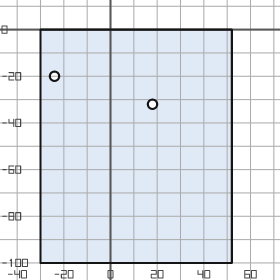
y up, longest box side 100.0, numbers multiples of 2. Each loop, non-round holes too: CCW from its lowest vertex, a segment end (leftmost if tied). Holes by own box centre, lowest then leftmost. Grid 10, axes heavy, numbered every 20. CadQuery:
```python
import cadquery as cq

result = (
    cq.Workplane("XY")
    .moveTo(-30.0, -100.0)
    .lineTo(52.0, -100.0)
    .lineTo(52.0, 0.0)
    .lineTo(-30.0, 0.0)
    .close()
    .moveTo(18.0, -32.0)
    .circle(2.0)
    .moveTo(-24.0, -20.0)
    .circle(2.0)
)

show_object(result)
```